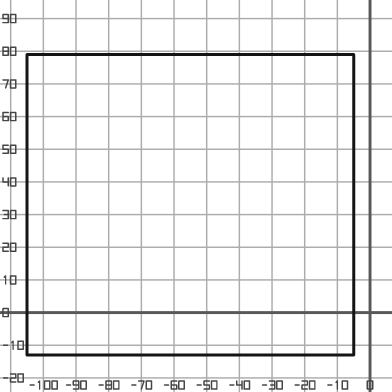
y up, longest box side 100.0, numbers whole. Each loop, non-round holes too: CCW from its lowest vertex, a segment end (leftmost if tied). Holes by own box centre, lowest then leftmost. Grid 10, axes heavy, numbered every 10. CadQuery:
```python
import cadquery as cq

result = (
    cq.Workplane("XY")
    .moveTo(-105.0, -13.0)
    .lineTo(-5.0, -13.0)
    .lineTo(-5.0, 79.0)
    .lineTo(-105.0, 79.0)
    .close()
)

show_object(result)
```